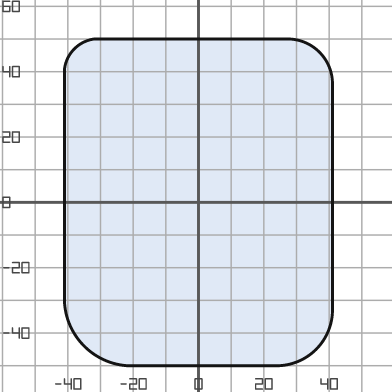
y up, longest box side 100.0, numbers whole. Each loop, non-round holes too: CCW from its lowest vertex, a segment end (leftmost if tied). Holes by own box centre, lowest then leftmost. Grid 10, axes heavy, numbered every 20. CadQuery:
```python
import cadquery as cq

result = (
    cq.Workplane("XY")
    .moveTo(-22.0, -50.0)
    .lineTo(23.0, -50.0)
    .threePointArc((36.0, -45.0), (41.0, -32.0))
    .lineTo(41.0, 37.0)
    .threePointArc((37.0, 46.0), (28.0, 50.0))
    .lineTo(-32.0, 50.0)
    .threePointArc((-38.0, 47.0), (-41.0, 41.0))
    .lineTo(-41.0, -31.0)
    .threePointArc((-35.0, -44.0), (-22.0, -50.0))
    .close()
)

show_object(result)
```